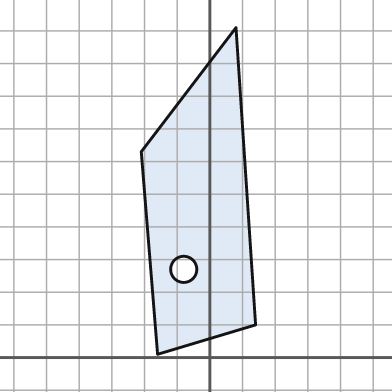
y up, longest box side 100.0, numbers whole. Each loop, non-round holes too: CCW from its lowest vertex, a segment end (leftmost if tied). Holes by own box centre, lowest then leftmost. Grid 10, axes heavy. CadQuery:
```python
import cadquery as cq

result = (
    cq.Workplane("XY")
    .moveTo(-16.0, 1.0)
    .lineTo(14.0, 10.0)
    .lineTo(8.0, 101.0)
    .lineTo(-21.0, 63.0)
    .close()
    .moveTo(-8.0, 27.0)
    .circle(4.0)
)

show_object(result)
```